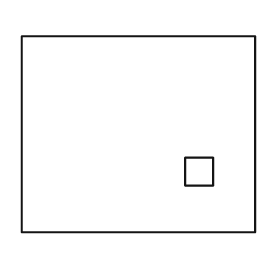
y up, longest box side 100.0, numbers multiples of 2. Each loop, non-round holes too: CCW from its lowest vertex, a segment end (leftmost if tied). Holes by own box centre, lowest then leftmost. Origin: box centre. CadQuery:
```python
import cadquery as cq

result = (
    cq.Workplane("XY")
    .moveTo(-50.0, -42.0)
    .lineTo(50.0, -42.0)
    .lineTo(50.0, 42.0)
    .lineTo(-50.0, 42.0)
    .close()
    .moveTo(20.0, -22.0)
    .lineTo(32.0, -22.0)
    .lineTo(32.0, -10.0)
    .lineTo(20.0, -10.0)
    .close()
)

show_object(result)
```